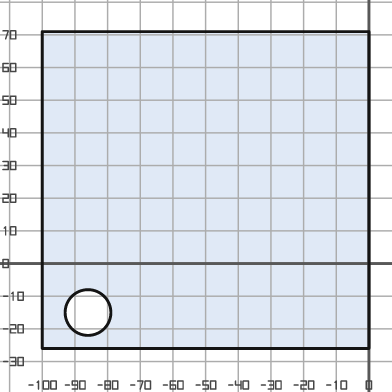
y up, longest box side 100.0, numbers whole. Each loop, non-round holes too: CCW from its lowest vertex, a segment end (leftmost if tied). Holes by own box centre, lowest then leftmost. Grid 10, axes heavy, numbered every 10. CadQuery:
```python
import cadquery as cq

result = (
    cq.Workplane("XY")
    .moveTo(-100.0, -26.0)
    .lineTo(0.0, -26.0)
    .lineTo(0.0, 71.0)
    .lineTo(-100.0, 71.0)
    .close()
    .moveTo(-86.0, -15.0)
    .circle(7.0)
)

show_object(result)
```